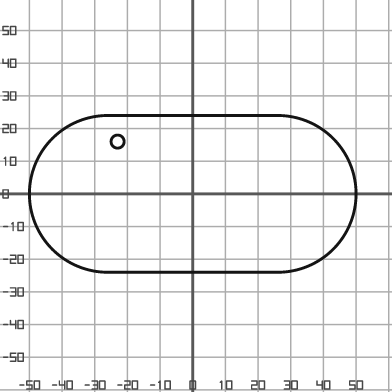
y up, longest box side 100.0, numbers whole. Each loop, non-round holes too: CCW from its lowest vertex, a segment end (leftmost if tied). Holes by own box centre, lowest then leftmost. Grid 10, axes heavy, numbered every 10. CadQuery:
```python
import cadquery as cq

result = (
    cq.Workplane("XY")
    .moveTo(-26.0, -24.0)
    .lineTo(26.0, -24.0)
    .threePointArc((50.0, 0.0), (26.0, 24.0))
    .lineTo(-26.0, 24.0)
    .threePointArc((-50.0, 0.0), (-26.0, -24.0))
    .close()
    .moveTo(-23.0, 16.0)
    .circle(2.0)
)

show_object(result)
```